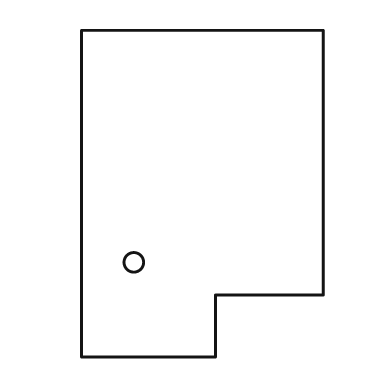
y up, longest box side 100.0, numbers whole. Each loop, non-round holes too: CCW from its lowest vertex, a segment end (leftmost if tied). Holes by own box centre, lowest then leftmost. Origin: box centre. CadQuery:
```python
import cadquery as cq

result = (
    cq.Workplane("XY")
    .moveTo(-37.0, -50.0)
    .lineTo(4.0, -50.0)
    .lineTo(4.0, -31.0)
    .lineTo(37.0, -31.0)
    .lineTo(37.0, 50.0)
    .lineTo(-37.0, 50.0)
    .close()
    .moveTo(-21.0, -21.0)
    .circle(3.0)
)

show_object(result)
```